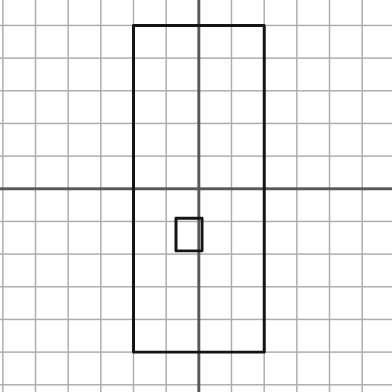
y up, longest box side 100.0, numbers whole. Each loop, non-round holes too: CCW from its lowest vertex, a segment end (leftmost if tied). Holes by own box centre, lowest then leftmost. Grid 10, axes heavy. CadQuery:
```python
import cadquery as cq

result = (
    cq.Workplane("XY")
    .moveTo(-20.0, -50.0)
    .lineTo(20.0, -50.0)
    .lineTo(20.0, 50.0)
    .lineTo(-20.0, 50.0)
    .close()
    .moveTo(-7.0, -19.0)
    .lineTo(1.0, -19.0)
    .lineTo(1.0, -9.0)
    .lineTo(-7.0, -9.0)
    .close()
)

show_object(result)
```